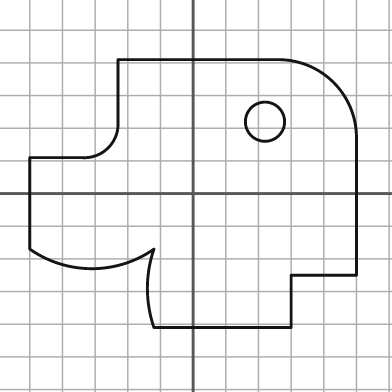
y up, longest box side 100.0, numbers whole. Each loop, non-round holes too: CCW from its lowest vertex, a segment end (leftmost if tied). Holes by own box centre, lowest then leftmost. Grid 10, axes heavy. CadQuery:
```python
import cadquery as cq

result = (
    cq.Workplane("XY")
    .moveTo(-12.0, -41.0)
    .lineTo(30.0, -41.0)
    .lineTo(30.0, -25.0)
    .lineTo(50.0, -25.0)
    .lineTo(50.0, 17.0)
    .threePointArc((43.0, 34.0), (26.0, 41.0))
    .lineTo(-23.0, 41.0)
    .lineTo(-23.0, 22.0)
    .threePointArc((-26.0, 14.0), (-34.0, 11.0))
    .lineTo(-50.0, 11.0)
    .lineTo(-50.0, -17.0)
    .threePointArc((-31.0, -23.0), (-12.0, -17.0))
    .threePointArc((-14.0, -29.0), (-12.0, -41.0))
    .close()
    .moveTo(22.0, 22.0)
    .circle(6.0)
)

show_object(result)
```